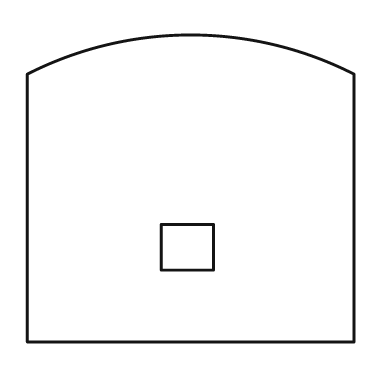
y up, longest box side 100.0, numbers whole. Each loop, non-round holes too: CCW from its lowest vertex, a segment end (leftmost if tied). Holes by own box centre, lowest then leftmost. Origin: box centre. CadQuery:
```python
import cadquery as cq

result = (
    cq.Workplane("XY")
    .moveTo(-50.0, -47.0)
    .lineTo(50.0, -47.0)
    .lineTo(50.0, 35.0)
    .threePointArc((0.0, 47.0), (-50.0, 35.0))
    .close()
    .moveTo(-9.0, -25.0)
    .lineTo(7.0, -25.0)
    .lineTo(7.0, -11.0)
    .lineTo(-9.0, -11.0)
    .close()
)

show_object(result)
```